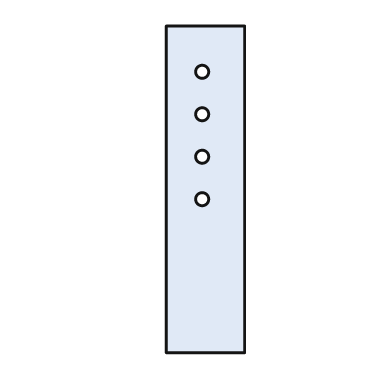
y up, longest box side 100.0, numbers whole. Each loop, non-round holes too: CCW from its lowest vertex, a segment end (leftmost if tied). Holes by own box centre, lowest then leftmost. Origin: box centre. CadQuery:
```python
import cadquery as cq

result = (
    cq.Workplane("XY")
    .moveTo(-12.0, -50.0)
    .lineTo(12.0, -50.0)
    .lineTo(12.0, 50.0)
    .lineTo(-12.0, 50.0)
    .close()
    .moveTo(-1.0, -3.0)
    .circle(2.0)
    .moveTo(-1.0, 10.0)
    .circle(2.0)
    .moveTo(-1.0, 23.0)
    .circle(2.0)
    .moveTo(-1.0, 36.0)
    .circle(2.0)
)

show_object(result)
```